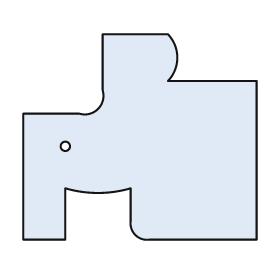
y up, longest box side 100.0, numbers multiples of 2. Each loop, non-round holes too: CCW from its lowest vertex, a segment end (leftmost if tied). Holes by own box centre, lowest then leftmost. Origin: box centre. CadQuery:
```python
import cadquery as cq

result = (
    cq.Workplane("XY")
    .moveTo(-50.0, -44.0)
    .lineTo(-32.0, -44.0)
    .lineTo(-32.0, -22.0)
    .threePointArc((-18.0, -24.0), (-4.0, -22.0))
    .lineTo(-4.0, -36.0)
    .threePointArc((-2.0, -42.0), (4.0, -44.0))
    .lineTo(50.0, -44.0)
    .lineTo(50.0, 24.0)
    .lineTo(12.0, 24.0)
    .threePointArc((16.0, 34.0), (12.0, 44.0))
    .lineTo(-16.0, 44.0)
    .lineTo(-16.0, 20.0)
    .threePointArc((-18.0, 12.0), (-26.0, 10.0))
    .lineTo(-50.0, 10.0)
    .close()
    .moveTo(-32.0, -4.0)
    .circle(2.0)
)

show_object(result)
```